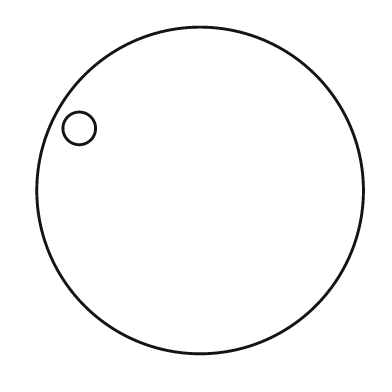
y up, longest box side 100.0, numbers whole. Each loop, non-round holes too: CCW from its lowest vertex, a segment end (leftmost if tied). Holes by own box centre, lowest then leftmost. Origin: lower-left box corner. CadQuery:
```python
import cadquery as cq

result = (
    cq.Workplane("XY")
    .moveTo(50.0, 50.0)
    .circle(50.0)
    .moveTo(13.0, 69.0)
    .circle(5.0)
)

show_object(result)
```